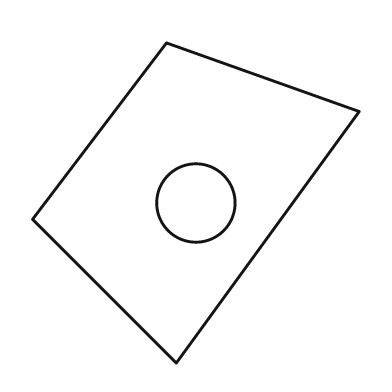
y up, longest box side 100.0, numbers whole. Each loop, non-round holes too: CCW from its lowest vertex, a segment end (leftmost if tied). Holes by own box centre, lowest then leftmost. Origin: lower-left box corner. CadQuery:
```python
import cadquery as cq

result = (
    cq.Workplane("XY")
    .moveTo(44.0, 0.0)
    .lineTo(100.0, 77.0)
    .lineTo(41.0, 98.0)
    .lineTo(0.0, 44.0)
    .close()
    .moveTo(50.0, 49.0)
    .circle(12.0)
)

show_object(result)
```